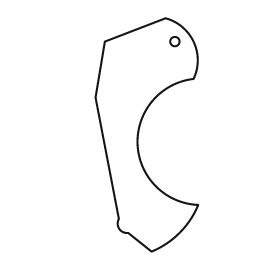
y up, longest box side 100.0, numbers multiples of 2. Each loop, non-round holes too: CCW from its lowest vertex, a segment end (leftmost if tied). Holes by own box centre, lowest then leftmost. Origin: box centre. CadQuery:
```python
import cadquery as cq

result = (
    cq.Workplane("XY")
    .moveTo(2.0, -50.0)
    .threePointArc((14.0, -42.0), (22.0, -30.0))
    .threePointArc((-4.0, -4.0), (20.0, 24.0))
    .threePointArc((20.0, 40.0), (8.0, 50.0))
    .lineTo(-18.0, 40.0)
    .lineTo(-22.0, 16.0)
    .lineTo(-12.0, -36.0)
    .threePointArc((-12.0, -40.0), (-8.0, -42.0))
    .close()
    .moveTo(12.0, 40.0)
    .circle(2.0)
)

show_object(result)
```